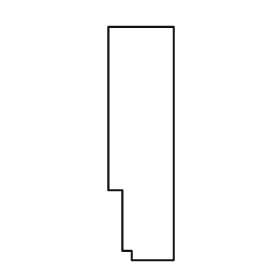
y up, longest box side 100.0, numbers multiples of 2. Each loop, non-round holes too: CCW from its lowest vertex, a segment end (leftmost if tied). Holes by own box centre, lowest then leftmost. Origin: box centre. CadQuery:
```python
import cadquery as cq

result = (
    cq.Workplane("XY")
    .moveTo(-4.0, -50.0)
    .lineTo(14.0, -50.0)
    .lineTo(14.0, 50.0)
    .lineTo(-14.0, 50.0)
    .lineTo(-14.0, -20.0)
    .lineTo(-8.0, -20.0)
    .lineTo(-8.0, -46.0)
    .lineTo(-4.0, -46.0)
    .close()
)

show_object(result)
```